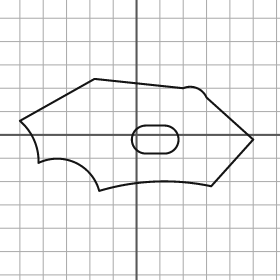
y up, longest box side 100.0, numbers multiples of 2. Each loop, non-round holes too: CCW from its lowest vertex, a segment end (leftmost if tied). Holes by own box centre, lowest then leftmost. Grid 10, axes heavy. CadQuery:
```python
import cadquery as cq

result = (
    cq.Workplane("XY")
    .moveTo(-16.0, -24.0)
    .threePointArc((8.0, -20.0), (32.0, -22.0))
    .lineTo(50.0, -2.0)
    .lineTo(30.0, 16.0)
    .threePointArc((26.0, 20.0), (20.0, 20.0))
    .lineTo(-18.0, 24.0)
    .lineTo(-50.0, 6.0)
    .threePointArc((-44.0, -2.0), (-42.0, -12.0))
    .threePointArc((-26.0, -12.0), (-16.0, -24.0))
    .close()
    .moveTo(4.0, -8.0)
    .lineTo(12.0, -8.0)
    .threePointArc((18.0, -2.0), (12.0, 4.0))
    .lineTo(4.0, 4.0)
    .threePointArc((-2.0, -2.0), (4.0, -8.0))
    .close()
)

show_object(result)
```